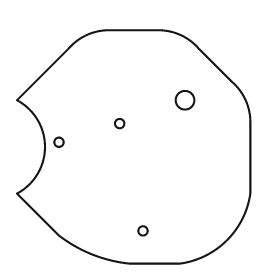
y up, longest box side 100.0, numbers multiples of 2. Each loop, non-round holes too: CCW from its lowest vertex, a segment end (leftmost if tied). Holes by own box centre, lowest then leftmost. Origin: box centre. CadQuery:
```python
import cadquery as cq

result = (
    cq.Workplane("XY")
    .moveTo(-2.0, -50.0)
    .lineTo(20.0, -50.0)
    .threePointArc((40.0, -40.0), (50.0, -20.0))
    .lineTo(50.0, 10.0)
    .threePointArc((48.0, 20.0), (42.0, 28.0))
    .lineTo(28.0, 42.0)
    .threePointArc((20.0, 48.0), (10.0, 50.0))
    .lineTo(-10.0, 50.0)
    .threePointArc((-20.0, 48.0), (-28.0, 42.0))
    .lineTo(-50.0, 20.0)
    .threePointArc((-38.0, 0.0), (-50.0, -20.0))
    .lineTo(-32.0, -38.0)
    .threePointArc((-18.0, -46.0), (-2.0, -50.0))
    .close()
    .moveTo(4.0, -36.0)
    .circle(2.0)
    .moveTo(-32.0, 2.0)
    .circle(2.0)
    .moveTo(-6.0, 10.0)
    .circle(2.0)
    .moveTo(22.0, 20.0)
    .circle(4.0)
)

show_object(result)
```